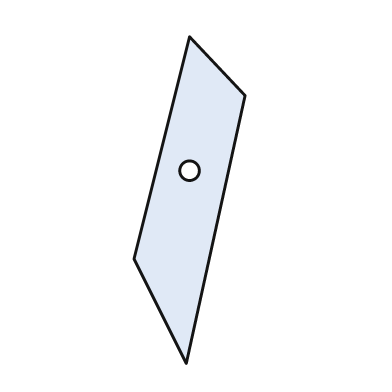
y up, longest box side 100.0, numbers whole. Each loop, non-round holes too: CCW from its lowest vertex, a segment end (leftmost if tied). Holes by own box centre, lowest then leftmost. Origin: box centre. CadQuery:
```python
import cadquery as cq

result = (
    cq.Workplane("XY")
    .moveTo(-1.0, -50.0)
    .lineTo(17.0, 32.0)
    .lineTo(0.0, 50.0)
    .lineTo(-17.0, -18.0)
    .close()
    .moveTo(0.0, 9.0)
    .circle(3.0)
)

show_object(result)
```